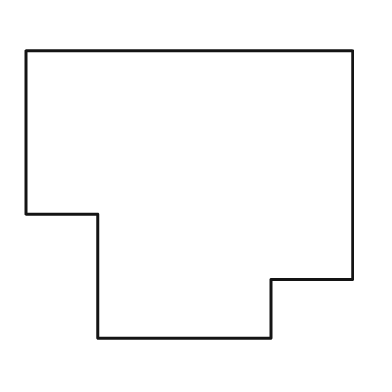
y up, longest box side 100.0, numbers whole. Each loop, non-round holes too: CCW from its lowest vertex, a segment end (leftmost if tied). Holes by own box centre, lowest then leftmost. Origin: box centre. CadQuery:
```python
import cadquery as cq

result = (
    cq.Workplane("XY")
    .moveTo(-28.0, -44.0)
    .lineTo(25.0, -44.0)
    .lineTo(25.0, -26.0)
    .lineTo(50.0, -26.0)
    .lineTo(50.0, 44.0)
    .lineTo(-50.0, 44.0)
    .lineTo(-50.0, -6.0)
    .lineTo(-28.0, -6.0)
    .close()
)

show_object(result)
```